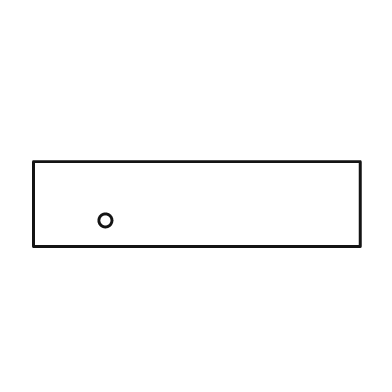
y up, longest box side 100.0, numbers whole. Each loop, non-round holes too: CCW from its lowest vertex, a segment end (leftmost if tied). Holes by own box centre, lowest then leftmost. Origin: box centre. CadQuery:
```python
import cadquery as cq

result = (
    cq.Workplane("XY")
    .moveTo(-50.0, -13.0)
    .lineTo(50.0, -13.0)
    .lineTo(50.0, 13.0)
    .lineTo(-50.0, 13.0)
    .close()
    .moveTo(-28.0, -5.0)
    .circle(2.0)
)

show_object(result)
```